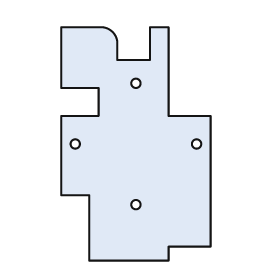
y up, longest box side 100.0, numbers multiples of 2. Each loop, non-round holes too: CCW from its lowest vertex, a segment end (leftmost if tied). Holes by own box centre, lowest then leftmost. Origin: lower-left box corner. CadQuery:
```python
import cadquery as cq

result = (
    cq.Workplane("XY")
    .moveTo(12.0, 0.0)
    .lineTo(46.0, 0.0)
    .lineTo(46.0, 6.0)
    .lineTo(64.0, 6.0)
    .lineTo(64.0, 62.0)
    .lineTo(46.0, 62.0)
    .lineTo(46.0, 100.0)
    .lineTo(38.0, 100.0)
    .lineTo(38.0, 86.0)
    .lineTo(24.0, 86.0)
    .lineTo(24.0, 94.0)
    .threePointArc((22.0, 98.0), (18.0, 100.0))
    .lineTo(0.0, 100.0)
    .lineTo(0.0, 74.0)
    .lineTo(16.0, 74.0)
    .lineTo(16.0, 62.0)
    .lineTo(0.0, 62.0)
    .lineTo(0.0, 28.0)
    .lineTo(12.0, 28.0)
    .close()
    .moveTo(32.0, 24.0)
    .circle(2.0)
    .moveTo(6.0, 50.0)
    .circle(2.0)
    .moveTo(58.0, 50.0)
    .circle(2.0)
    .moveTo(32.0, 76.0)
    .circle(2.0)
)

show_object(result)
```